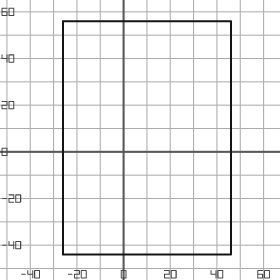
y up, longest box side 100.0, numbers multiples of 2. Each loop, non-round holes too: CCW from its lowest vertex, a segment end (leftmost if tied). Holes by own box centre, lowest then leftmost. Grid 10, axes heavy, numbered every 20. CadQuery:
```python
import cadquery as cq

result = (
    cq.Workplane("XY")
    .moveTo(-26.0, -44.0)
    .lineTo(46.0, -44.0)
    .lineTo(46.0, 56.0)
    .lineTo(-26.0, 56.0)
    .close()
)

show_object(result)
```